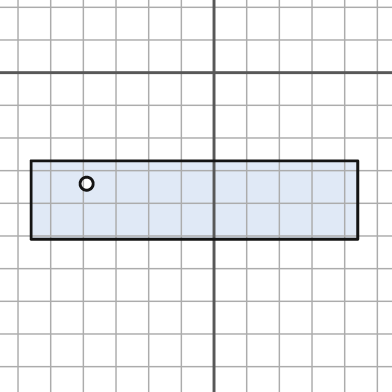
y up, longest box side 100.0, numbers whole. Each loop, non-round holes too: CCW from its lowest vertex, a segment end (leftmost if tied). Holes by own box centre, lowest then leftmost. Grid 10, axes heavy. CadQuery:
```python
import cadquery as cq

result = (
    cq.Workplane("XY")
    .moveTo(-56.0, -51.0)
    .lineTo(44.0, -51.0)
    .lineTo(44.0, -27.0)
    .lineTo(-56.0, -27.0)
    .close()
    .moveTo(-39.0, -34.0)
    .circle(2.0)
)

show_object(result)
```